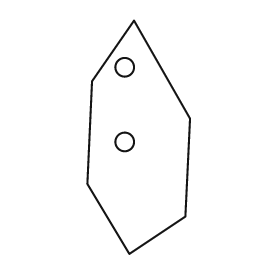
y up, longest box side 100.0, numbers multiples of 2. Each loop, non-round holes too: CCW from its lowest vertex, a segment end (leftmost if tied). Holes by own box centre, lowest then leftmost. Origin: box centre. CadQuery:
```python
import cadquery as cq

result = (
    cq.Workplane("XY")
    .moveTo(-4.0, -50.0)
    .lineTo(20.0, -34.0)
    .lineTo(22.0, 8.0)
    .lineTo(-2.0, 50.0)
    .lineTo(-20.0, 24.0)
    .lineTo(-22.0, -20.0)
    .close()
    .moveTo(-6.0, -2.0)
    .circle(4.0)
    .moveTo(-6.0, 30.0)
    .circle(4.0)
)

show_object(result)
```